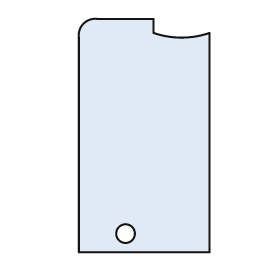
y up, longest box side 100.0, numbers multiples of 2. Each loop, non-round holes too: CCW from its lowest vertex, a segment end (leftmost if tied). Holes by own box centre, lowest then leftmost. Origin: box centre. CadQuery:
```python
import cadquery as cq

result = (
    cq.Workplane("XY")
    .moveTo(-28.0, -50.0)
    .lineTo(28.0, -50.0)
    .lineTo(28.0, 44.0)
    .threePointArc((16.0, 42.0), (4.0, 44.0))
    .lineTo(4.0, 50.0)
    .lineTo(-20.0, 50.0)
    .threePointArc((-26.0, 48.0), (-28.0, 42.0))
    .close()
    .moveTo(-8.0, -42.0)
    .circle(4.0)
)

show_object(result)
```